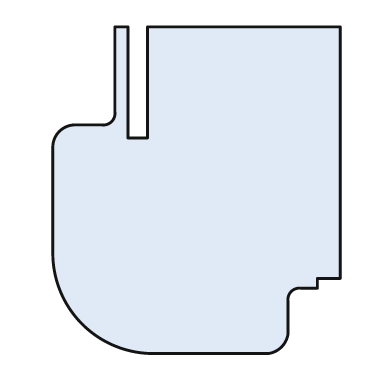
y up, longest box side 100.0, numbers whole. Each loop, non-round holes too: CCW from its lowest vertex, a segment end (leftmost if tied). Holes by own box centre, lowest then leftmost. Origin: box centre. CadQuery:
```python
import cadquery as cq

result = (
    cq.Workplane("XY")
    .moveTo(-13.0, -50.0)
    .lineTo(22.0, -50.0)
    .threePointArc((26.0, -48.0), (28.0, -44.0))
    .lineTo(28.0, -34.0)
    .threePointArc((29.0, -31.0), (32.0, -30.0))
    .lineTo(37.0, -30.0)
    .lineTo(37.0, -27.0)
    .lineTo(44.0, -27.0)
    .lineTo(44.0, 50.0)
    .lineTo(-15.0, 50.0)
    .lineTo(-15.0, 16.0)
    .lineTo(-21.0, 16.0)
    .lineTo(-21.0, 50.0)
    .lineTo(-25.0, 50.0)
    .lineTo(-25.0, 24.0)
    .threePointArc((-26.0, 21.0), (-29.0, 20.0))
    .lineTo(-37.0, 20.0)
    .threePointArc((-42.0, 18.0), (-44.0, 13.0))
    .lineTo(-44.0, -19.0)
    .threePointArc((-35.0, -41.0), (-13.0, -50.0))
    .close()
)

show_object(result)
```